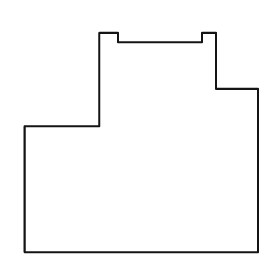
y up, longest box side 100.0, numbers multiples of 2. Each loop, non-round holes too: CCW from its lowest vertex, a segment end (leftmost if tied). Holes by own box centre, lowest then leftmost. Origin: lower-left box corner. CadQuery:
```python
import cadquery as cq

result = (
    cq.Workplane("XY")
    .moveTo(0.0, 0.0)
    .lineTo(100.0, 0.0)
    .lineTo(100.0, 70.0)
    .lineTo(82.0, 70.0)
    .lineTo(82.0, 94.0)
    .lineTo(76.0, 94.0)
    .lineTo(76.0, 90.0)
    .lineTo(40.0, 90.0)
    .lineTo(40.0, 94.0)
    .lineTo(32.0, 94.0)
    .lineTo(32.0, 54.0)
    .lineTo(0.0, 54.0)
    .close()
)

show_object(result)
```